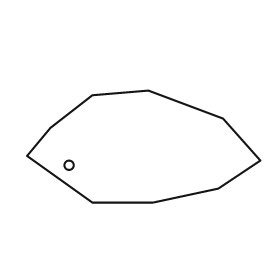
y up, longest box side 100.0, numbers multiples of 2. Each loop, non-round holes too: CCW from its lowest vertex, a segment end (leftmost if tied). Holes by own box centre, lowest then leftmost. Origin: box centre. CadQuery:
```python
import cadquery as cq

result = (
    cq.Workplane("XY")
    .moveTo(-22.0, -24.0)
    .lineTo(4.0, -24.0)
    .lineTo(32.0, -18.0)
    .lineTo(50.0, -6.0)
    .lineTo(34.0, 12.0)
    .lineTo(2.0, 24.0)
    .lineTo(-22.0, 22.0)
    .lineTo(-40.0, 8.0)
    .lineTo(-50.0, -4.0)
    .close()
    .moveTo(-32.0, -8.0)
    .circle(2.0)
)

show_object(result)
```